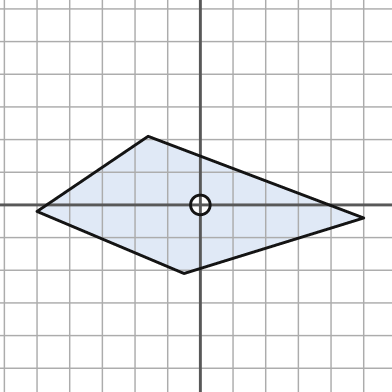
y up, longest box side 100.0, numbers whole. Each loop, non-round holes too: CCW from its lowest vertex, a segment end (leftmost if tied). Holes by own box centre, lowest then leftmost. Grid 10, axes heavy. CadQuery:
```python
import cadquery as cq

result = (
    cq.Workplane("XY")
    .moveTo(-5.0, -21.0)
    .lineTo(50.0, -4.0)
    .lineTo(-16.0, 21.0)
    .lineTo(-50.0, -2.0)
    .close()
    .moveTo(0.0, 0.0)
    .circle(3.0)
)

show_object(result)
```